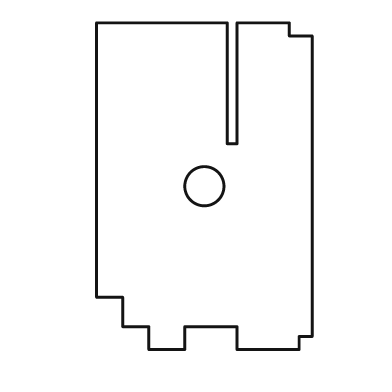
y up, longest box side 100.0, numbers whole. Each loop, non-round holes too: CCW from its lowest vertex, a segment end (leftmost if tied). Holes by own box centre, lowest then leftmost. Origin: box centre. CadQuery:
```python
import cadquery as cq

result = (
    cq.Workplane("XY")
    .moveTo(-17.0, -50.0)
    .lineTo(-6.0, -50.0)
    .lineTo(-6.0, -43.0)
    .lineTo(10.0, -43.0)
    .lineTo(10.0, -50.0)
    .lineTo(29.0, -50.0)
    .lineTo(29.0, -46.0)
    .lineTo(33.0, -46.0)
    .lineTo(33.0, 46.0)
    .lineTo(26.0, 46.0)
    .lineTo(26.0, 50.0)
    .lineTo(10.0, 50.0)
    .lineTo(10.0, 13.0)
    .lineTo(7.0, 13.0)
    .lineTo(7.0, 50.0)
    .lineTo(-33.0, 50.0)
    .lineTo(-33.0, -34.0)
    .lineTo(-25.0, -34.0)
    .lineTo(-25.0, -43.0)
    .lineTo(-17.0, -43.0)
    .close()
    .moveTo(0.0, 0.0)
    .circle(6.0)
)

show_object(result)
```